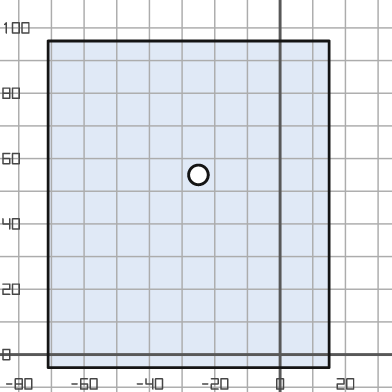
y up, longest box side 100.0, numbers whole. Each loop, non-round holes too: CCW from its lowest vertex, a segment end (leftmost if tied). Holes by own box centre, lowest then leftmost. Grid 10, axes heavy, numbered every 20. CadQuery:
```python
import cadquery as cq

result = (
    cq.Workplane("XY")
    .moveTo(-71.0, -4.0)
    .lineTo(15.0, -4.0)
    .lineTo(15.0, 96.0)
    .lineTo(-71.0, 96.0)
    .close()
    .moveTo(-25.0, 55.0)
    .circle(3.0)
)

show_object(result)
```